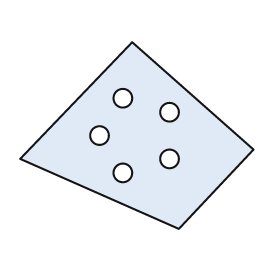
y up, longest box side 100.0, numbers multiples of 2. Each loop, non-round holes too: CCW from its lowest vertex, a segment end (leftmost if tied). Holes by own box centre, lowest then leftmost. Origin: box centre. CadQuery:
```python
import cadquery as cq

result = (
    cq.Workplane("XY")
    .moveTo(18.0, -40.0)
    .lineTo(50.0, -6.0)
    .lineTo(-2.0, 40.0)
    .lineTo(-50.0, -10.0)
    .close()
    .moveTo(-6.0, -16.0)
    .circle(4.0)
    .moveTo(14.0, -10.0)
    .circle(4.0)
    .moveTo(-16.0, 0.0)
    .circle(4.0)
    .moveTo(14.0, 10.0)
    .circle(4.0)
    .moveTo(-6.0, 16.0)
    .circle(4.0)
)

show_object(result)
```